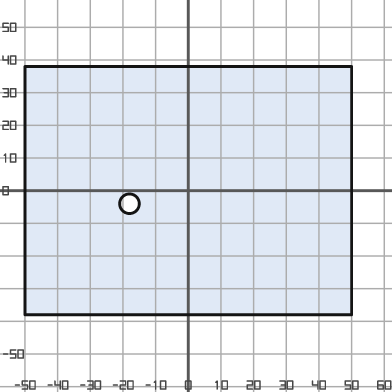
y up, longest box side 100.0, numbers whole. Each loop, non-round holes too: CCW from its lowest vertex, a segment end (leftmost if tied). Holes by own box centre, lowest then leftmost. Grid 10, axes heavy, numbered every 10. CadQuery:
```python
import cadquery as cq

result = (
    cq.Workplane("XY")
    .moveTo(-50.0, -38.0)
    .lineTo(50.0, -38.0)
    .lineTo(50.0, 38.0)
    .lineTo(-50.0, 38.0)
    .close()
    .moveTo(-18.0, -4.0)
    .circle(3.0)
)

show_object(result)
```